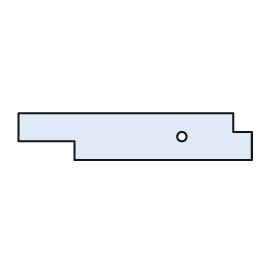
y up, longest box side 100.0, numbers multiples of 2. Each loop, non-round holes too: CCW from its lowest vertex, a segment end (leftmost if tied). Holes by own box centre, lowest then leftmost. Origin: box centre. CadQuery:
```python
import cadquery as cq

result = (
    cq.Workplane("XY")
    .moveTo(-26.0, -10.0)
    .lineTo(50.0, -10.0)
    .lineTo(50.0, 2.0)
    .lineTo(42.0, 2.0)
    .lineTo(42.0, 10.0)
    .lineTo(-50.0, 10.0)
    .lineTo(-50.0, -2.0)
    .lineTo(-26.0, -2.0)
    .close()
    .moveTo(20.0, 0.0)
    .circle(2.0)
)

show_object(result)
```